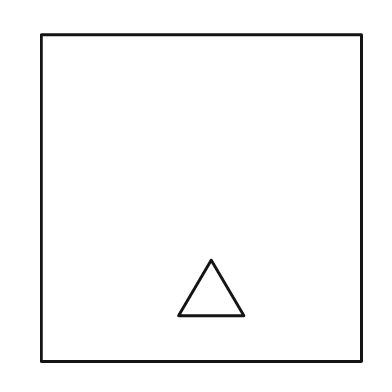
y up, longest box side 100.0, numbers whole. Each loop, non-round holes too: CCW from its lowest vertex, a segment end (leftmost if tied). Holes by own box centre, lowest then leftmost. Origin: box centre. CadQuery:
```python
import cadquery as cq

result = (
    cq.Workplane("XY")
    .moveTo(-49.0, -50.0)
    .lineTo(49.0, -50.0)
    .lineTo(49.0, 50.0)
    .lineTo(-49.0, 50.0)
    .close()
    .moveTo(-7.0, -36.0)
    .lineTo(13.0, -36.0)
    .lineTo(3.0, -19.0)
    .close()
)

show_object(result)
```